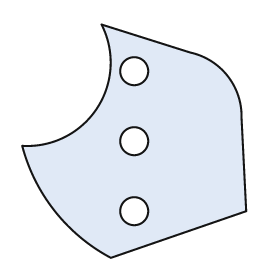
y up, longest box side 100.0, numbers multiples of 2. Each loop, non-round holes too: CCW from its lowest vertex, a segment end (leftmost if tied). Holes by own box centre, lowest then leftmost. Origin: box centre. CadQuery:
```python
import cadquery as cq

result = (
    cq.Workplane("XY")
    .moveTo(-10.0, -50.0)
    .lineTo(48.0, -30.0)
    .lineTo(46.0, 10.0)
    .threePointArc((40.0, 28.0), (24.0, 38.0))
    .lineTo(-14.0, 50.0)
    .threePointArc((-16.0, 14.0), (-48.0, -2.0))
    .threePointArc((-34.0, -30.0), (-10.0, -50.0))
    .close()
    .moveTo(0.0, -30.0)
    .circle(6.0)
    .moveTo(0.0, 0.0)
    .circle(6.0)
    .moveTo(0.0, 30.0)
    .circle(6.0)
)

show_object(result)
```